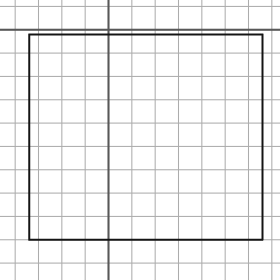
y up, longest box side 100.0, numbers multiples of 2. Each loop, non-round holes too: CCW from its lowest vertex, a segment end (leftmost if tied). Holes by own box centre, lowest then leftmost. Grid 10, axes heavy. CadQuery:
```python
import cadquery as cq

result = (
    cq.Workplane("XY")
    .moveTo(-34.0, -90.0)
    .lineTo(66.0, -90.0)
    .lineTo(66.0, -2.0)
    .lineTo(-34.0, -2.0)
    .close()
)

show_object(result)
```